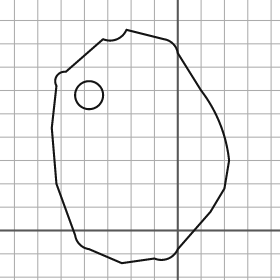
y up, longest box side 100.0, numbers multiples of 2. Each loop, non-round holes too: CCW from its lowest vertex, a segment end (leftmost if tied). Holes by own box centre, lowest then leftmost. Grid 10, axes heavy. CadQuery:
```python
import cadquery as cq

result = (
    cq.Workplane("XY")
    .moveTo(-24.0, -14.0)
    .lineTo(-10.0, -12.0)
    .threePointArc((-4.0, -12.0), (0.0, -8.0))
    .lineTo(14.0, 8.0)
    .lineTo(20.0, 18.0)
    .lineTo(22.0, 30.0)
    .threePointArc((18.0, 46.0), (10.0, 60.0))
    .lineTo(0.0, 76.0)
    .threePointArc((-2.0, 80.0), (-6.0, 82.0))
    .lineTo(-22.0, 86.0)
    .threePointArc((-26.0, 82.0), (-32.0, 82.0))
    .lineTo(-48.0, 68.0)
    .threePointArc((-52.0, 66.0), (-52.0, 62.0))
    .lineTo(-54.0, 44.0)
    .lineTo(-52.0, 20.0)
    .lineTo(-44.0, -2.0)
    .threePointArc((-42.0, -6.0), (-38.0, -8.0))
    .close()
    .moveTo(-38.0, 58.0)
    .circle(6.0)
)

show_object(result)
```